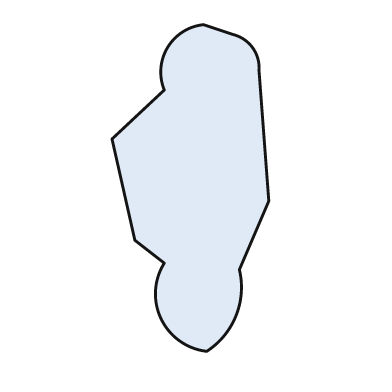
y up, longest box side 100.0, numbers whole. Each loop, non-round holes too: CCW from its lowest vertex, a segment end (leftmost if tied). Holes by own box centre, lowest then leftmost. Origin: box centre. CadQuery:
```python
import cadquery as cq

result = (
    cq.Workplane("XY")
    .moveTo(5.0, -50.0)
    .threePointArc((14.0, -39.0), (15.0, -25.0))
    .lineTo(24.0, -4.0)
    .lineTo(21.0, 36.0)
    .threePointArc((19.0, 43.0), (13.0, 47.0))
    .lineTo(4.0, 50.0)
    .threePointArc((-7.0, 43.0), (-8.0, 30.0))
    .lineTo(-24.0, 15.0)
    .lineTo(-17.0, -16.0)
    .lineTo(-8.0, -23.0)
    .threePointArc((-9.0, -40.0), (5.0, -50.0))
    .close()
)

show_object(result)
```